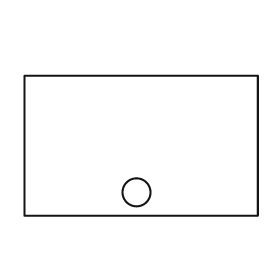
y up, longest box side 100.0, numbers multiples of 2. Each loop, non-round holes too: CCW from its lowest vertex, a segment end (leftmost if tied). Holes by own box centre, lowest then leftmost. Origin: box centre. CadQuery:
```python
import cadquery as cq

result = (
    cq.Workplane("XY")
    .moveTo(-50.0, -30.0)
    .lineTo(50.0, -30.0)
    .lineTo(50.0, 30.0)
    .lineTo(-50.0, 30.0)
    .close()
    .moveTo(-2.0, -20.0)
    .circle(6.0)
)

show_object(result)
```